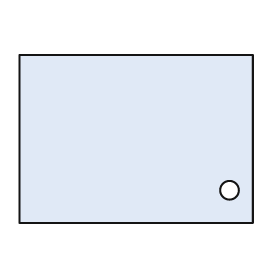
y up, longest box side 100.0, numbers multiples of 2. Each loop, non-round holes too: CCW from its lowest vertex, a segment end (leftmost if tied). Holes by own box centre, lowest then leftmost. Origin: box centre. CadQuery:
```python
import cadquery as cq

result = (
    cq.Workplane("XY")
    .moveTo(-50.0, -36.0)
    .lineTo(50.0, -36.0)
    .lineTo(50.0, 36.0)
    .lineTo(-50.0, 36.0)
    .close()
    .moveTo(40.0, -22.0)
    .circle(4.0)
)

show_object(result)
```